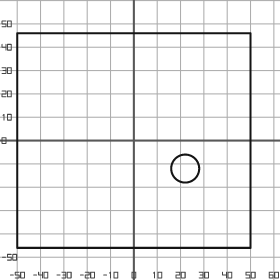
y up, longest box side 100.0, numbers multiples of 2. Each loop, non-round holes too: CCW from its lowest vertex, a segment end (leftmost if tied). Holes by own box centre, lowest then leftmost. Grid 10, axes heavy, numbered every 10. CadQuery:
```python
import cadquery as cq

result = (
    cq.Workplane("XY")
    .moveTo(-50.0, -46.0)
    .lineTo(50.0, -46.0)
    .lineTo(50.0, 46.0)
    .lineTo(-50.0, 46.0)
    .close()
    .moveTo(22.0, -12.0)
    .circle(6.0)
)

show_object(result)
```